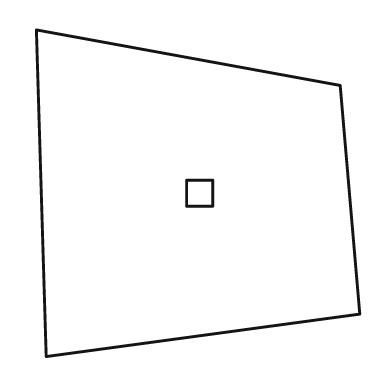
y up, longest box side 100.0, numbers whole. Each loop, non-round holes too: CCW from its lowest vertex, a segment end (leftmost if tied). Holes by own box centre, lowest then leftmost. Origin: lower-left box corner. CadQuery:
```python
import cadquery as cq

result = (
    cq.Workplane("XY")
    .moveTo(3.0, 0.0)
    .lineTo(99.0, 13.0)
    .lineTo(93.0, 83.0)
    .lineTo(0.0, 100.0)
    .close()
    .moveTo(46.0, 46.0)
    .lineTo(54.0, 46.0)
    .lineTo(54.0, 54.0)
    .lineTo(46.0, 54.0)
    .close()
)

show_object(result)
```